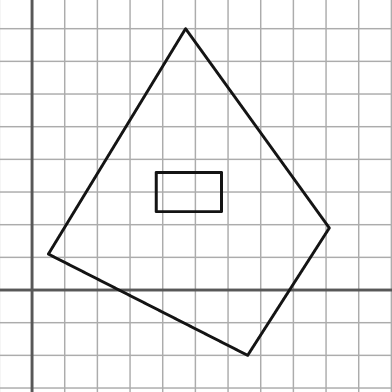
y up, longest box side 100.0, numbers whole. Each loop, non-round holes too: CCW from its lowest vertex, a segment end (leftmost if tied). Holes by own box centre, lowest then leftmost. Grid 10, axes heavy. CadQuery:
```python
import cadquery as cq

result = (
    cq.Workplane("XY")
    .moveTo(66.0, -20.0)
    .lineTo(91.0, 19.0)
    .lineTo(47.0, 80.0)
    .lineTo(5.0, 11.0)
    .close()
    .moveTo(38.0, 24.0)
    .lineTo(58.0, 24.0)
    .lineTo(58.0, 36.0)
    .lineTo(38.0, 36.0)
    .close()
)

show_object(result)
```